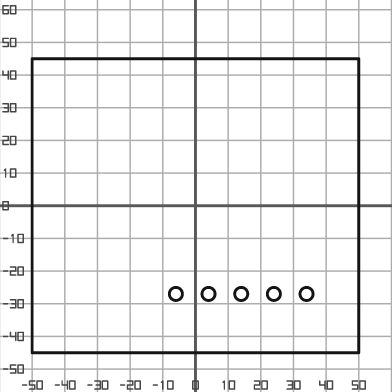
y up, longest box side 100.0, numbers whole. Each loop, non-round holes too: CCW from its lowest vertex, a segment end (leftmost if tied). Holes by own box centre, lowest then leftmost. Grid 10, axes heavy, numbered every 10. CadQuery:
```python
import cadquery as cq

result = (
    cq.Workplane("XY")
    .moveTo(-50.0, -45.0)
    .lineTo(50.0, -45.0)
    .lineTo(50.0, 45.0)
    .lineTo(-50.0, 45.0)
    .close()
    .moveTo(-6.0, -27.0)
    .circle(2.0)
    .moveTo(4.0, -27.0)
    .circle(2.0)
    .moveTo(14.0, -27.0)
    .circle(2.0)
    .moveTo(24.0, -27.0)
    .circle(2.0)
    .moveTo(34.0, -27.0)
    .circle(2.0)
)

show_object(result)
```